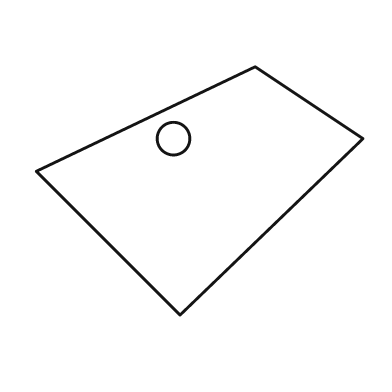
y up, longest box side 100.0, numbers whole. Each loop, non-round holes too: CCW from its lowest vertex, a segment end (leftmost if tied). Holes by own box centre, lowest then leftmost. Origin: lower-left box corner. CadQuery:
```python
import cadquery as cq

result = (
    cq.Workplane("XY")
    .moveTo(44.0, 0.0)
    .lineTo(100.0, 54.0)
    .lineTo(67.0, 76.0)
    .lineTo(0.0, 44.0)
    .close()
    .moveTo(42.0, 54.0)
    .circle(5.0)
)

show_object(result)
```